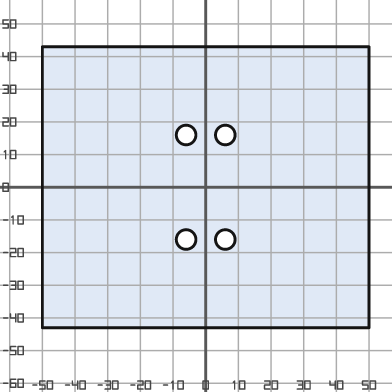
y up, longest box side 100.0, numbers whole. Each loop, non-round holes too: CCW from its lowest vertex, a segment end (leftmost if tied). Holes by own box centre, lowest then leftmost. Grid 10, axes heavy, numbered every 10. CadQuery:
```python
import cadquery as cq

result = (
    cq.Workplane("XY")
    .moveTo(-50.0, -43.0)
    .lineTo(50.0, -43.0)
    .lineTo(50.0, 43.0)
    .lineTo(-50.0, 43.0)
    .close()
    .moveTo(-6.0, -16.0)
    .circle(3.0)
    .moveTo(6.0, -16.0)
    .circle(3.0)
    .moveTo(-6.0, 16.0)
    .circle(3.0)
    .moveTo(6.0, 16.0)
    .circle(3.0)
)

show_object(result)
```